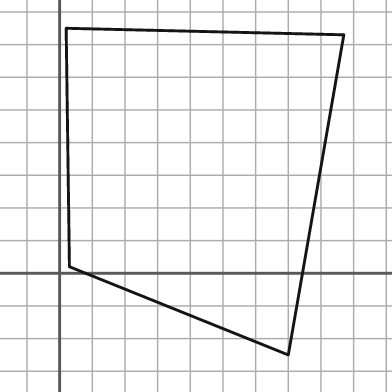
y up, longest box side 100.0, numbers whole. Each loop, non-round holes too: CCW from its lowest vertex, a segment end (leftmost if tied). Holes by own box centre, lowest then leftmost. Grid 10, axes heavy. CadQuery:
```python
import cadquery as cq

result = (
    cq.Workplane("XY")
    .moveTo(70.0, -25.0)
    .lineTo(87.0, 73.0)
    .lineTo(2.0, 75.0)
    .lineTo(3.0, 2.0)
    .close()
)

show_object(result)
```